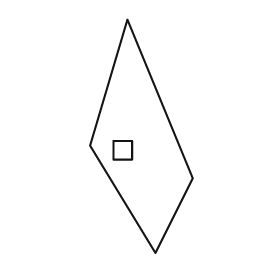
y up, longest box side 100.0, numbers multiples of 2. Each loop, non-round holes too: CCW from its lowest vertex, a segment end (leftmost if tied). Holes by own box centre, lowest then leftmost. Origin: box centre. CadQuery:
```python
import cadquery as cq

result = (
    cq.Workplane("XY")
    .moveTo(6.0, -50.0)
    .lineTo(22.0, -18.0)
    .lineTo(-6.0, 50.0)
    .lineTo(-22.0, -4.0)
    .close()
    .moveTo(-12.0, -10.0)
    .lineTo(-4.0, -10.0)
    .lineTo(-4.0, -2.0)
    .lineTo(-12.0, -2.0)
    .close()
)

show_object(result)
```